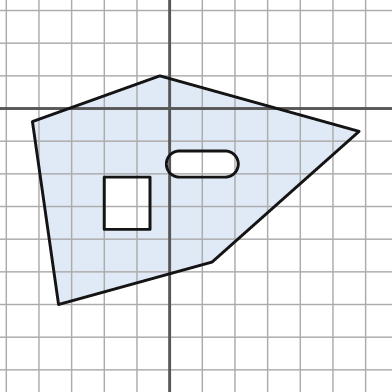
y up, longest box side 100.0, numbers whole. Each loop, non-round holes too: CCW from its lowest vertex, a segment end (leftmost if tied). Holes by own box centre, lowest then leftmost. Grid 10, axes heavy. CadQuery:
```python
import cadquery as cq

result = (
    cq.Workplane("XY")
    .moveTo(-34.0, -60.0)
    .lineTo(13.0, -47.0)
    .lineTo(58.0, -7.0)
    .lineTo(-3.0, 10.0)
    .lineTo(-42.0, -4.0)
    .close()
    .moveTo(-20.0, -37.0)
    .lineTo(-6.0, -37.0)
    .lineTo(-6.0, -21.0)
    .lineTo(-20.0, -21.0)
    .close()
    .moveTo(3.0, -21.0)
    .lineTo(17.0, -21.0)
    .threePointArc((21.0, -17.0), (17.0, -13.0))
    .lineTo(3.0, -13.0)
    .threePointArc((-1.0, -17.0), (3.0, -21.0))
    .close()
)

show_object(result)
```